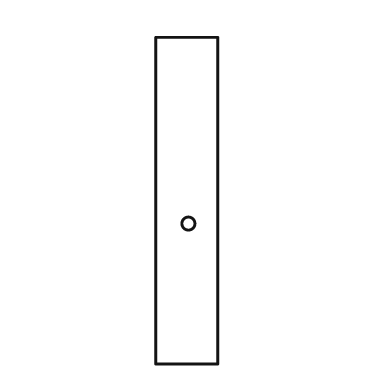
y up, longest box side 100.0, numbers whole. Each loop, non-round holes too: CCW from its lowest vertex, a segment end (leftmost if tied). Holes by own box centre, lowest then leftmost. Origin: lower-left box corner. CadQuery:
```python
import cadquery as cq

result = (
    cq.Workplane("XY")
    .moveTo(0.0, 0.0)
    .lineTo(19.0, 0.0)
    .lineTo(19.0, 100.0)
    .lineTo(0.0, 100.0)
    .close()
    .moveTo(10.0, 43.0)
    .circle(2.0)
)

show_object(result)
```